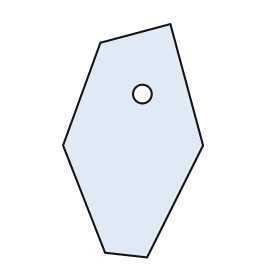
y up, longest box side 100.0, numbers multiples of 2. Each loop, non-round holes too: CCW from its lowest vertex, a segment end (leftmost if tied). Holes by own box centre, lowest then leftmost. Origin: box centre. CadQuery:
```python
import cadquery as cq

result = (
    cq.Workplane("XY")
    .moveTo(6.0, -50.0)
    .lineTo(30.0, -2.0)
    .lineTo(16.0, 50.0)
    .lineTo(-14.0, 42.0)
    .lineTo(-30.0, -2.0)
    .lineTo(-12.0, -48.0)
    .close()
    .moveTo(4.0, 20.0)
    .circle(4.0)
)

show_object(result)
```